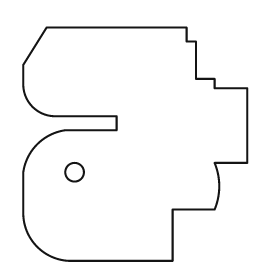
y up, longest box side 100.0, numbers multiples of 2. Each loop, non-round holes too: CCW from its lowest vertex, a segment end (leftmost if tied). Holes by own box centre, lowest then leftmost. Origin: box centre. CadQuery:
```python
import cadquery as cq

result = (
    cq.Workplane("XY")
    .moveTo(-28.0, -50.0)
    .lineTo(16.0, -50.0)
    .lineTo(16.0, -28.0)
    .lineTo(34.0, -28.0)
    .threePointArc((36.0, -18.0), (34.0, -8.0))
    .lineTo(48.0, -8.0)
    .lineTo(48.0, 24.0)
    .lineTo(34.0, 24.0)
    .lineTo(34.0, 28.0)
    .lineTo(26.0, 28.0)
    .lineTo(26.0, 44.0)
    .lineTo(22.0, 44.0)
    .lineTo(22.0, 50.0)
    .lineTo(-38.0, 50.0)
    .lineTo(-48.0, 34.0)
    .lineTo(-48.0, 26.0)
    .threePointArc((-44.0, 16.0), (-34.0, 12.0))
    .lineTo(-8.0, 12.0)
    .lineTo(-8.0, 6.0)
    .lineTo(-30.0, 6.0)
    .threePointArc((-42.0, 0.0), (-48.0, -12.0))
    .lineTo(-48.0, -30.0)
    .threePointArc((-42.0, -44.0), (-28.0, -50.0))
    .close()
    .moveTo(-26.0, -12.0)
    .circle(4.0)
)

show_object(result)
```